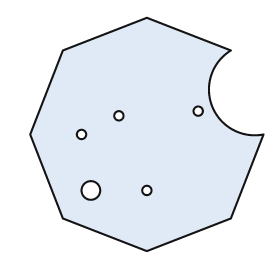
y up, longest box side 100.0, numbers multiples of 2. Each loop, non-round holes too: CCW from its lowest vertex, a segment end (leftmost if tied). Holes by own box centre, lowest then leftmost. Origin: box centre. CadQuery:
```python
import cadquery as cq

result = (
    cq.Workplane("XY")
    .moveTo(0.0, -50.0)
    .lineTo(36.0, -36.0)
    .lineTo(50.0, 0.0)
    .threePointArc((28.0, 12.0), (36.0, 36.0))
    .lineTo(0.0, 50.0)
    .lineTo(-36.0, 36.0)
    .lineTo(-50.0, 0.0)
    .lineTo(-36.0, -36.0)
    .close()
    .moveTo(-24.0, -24.0)
    .circle(4.0)
    .moveTo(0.0, -24.0)
    .circle(2.0)
    .moveTo(-28.0, 0.0)
    .circle(2.0)
    .moveTo(-12.0, 8.0)
    .circle(2.0)
    .moveTo(22.0, 10.0)
    .circle(2.0)
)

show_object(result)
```